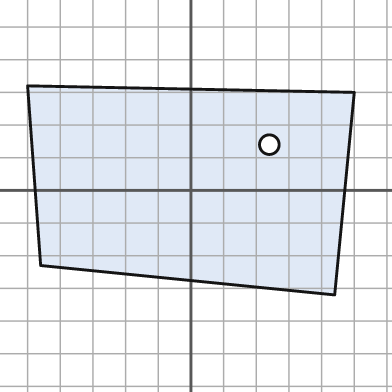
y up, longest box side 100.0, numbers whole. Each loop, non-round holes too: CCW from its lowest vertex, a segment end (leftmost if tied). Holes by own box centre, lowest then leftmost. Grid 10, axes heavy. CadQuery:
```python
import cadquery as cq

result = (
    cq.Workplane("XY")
    .moveTo(44.0, -32.0)
    .lineTo(50.0, 30.0)
    .lineTo(-50.0, 32.0)
    .lineTo(-46.0, -23.0)
    .close()
    .moveTo(24.0, 14.0)
    .circle(3.0)
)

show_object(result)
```